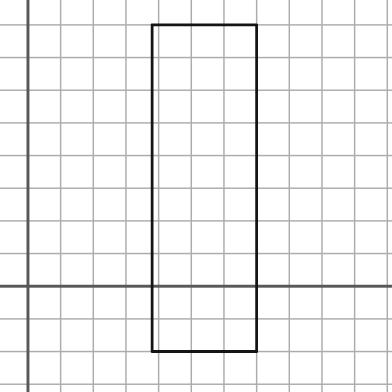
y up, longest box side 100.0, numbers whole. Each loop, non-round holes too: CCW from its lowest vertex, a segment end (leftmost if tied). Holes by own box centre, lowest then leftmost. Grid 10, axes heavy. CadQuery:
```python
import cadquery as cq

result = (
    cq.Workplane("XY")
    .moveTo(38.0, -20.0)
    .lineTo(70.0, -20.0)
    .lineTo(70.0, 80.0)
    .lineTo(38.0, 80.0)
    .close()
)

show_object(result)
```